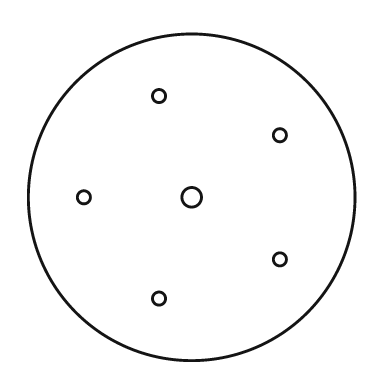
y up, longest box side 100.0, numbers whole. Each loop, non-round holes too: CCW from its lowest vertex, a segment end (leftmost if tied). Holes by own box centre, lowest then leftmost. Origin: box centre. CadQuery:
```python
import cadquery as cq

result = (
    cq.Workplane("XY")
    .moveTo(0.0, 0.0)
    .circle(50.0)
    .moveTo(-10.0, -31.0)
    .circle(2.0)
    .moveTo(27.0, -19.0)
    .circle(2.0)
    .moveTo(-33.0, 0.0)
    .circle(2.0)
    .moveTo(0.0, 0.0)
    .circle(3.0)
    .moveTo(27.0, 19.0)
    .circle(2.0)
    .moveTo(-10.0, 31.0)
    .circle(2.0)
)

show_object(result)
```